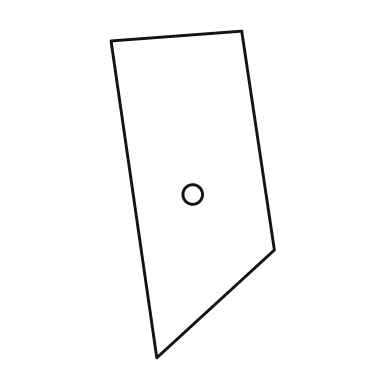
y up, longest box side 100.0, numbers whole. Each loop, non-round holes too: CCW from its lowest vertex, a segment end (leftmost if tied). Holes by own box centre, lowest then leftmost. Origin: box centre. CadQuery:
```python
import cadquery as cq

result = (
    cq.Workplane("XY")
    .moveTo(-11.0, -50.0)
    .lineTo(25.0, -17.0)
    .lineTo(15.0, 50.0)
    .lineTo(-25.0, 47.0)
    .close()
    .moveTo(0.0, 0.0)
    .circle(3.0)
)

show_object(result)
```